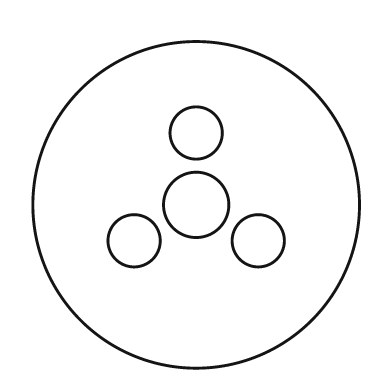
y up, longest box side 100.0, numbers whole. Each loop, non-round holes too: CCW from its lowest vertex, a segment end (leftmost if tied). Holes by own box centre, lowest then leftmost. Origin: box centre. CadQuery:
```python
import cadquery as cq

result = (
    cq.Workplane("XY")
    .moveTo(0.0, 0.0)
    .circle(50.0)
    .moveTo(-19.0, -11.0)
    .circle(8.0)
    .moveTo(19.0, -11.0)
    .circle(8.0)
    .moveTo(0.0, 0.0)
    .circle(10.0)
    .moveTo(0.0, 22.0)
    .circle(8.0)
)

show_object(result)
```